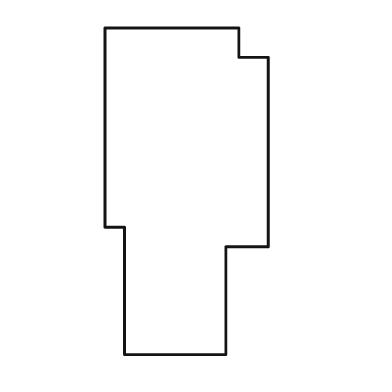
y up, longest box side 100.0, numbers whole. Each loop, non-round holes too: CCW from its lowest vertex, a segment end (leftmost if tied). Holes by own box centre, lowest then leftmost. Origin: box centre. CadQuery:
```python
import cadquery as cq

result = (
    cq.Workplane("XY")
    .moveTo(-19.0, -50.0)
    .lineTo(12.0, -50.0)
    .lineTo(12.0, -17.0)
    .lineTo(25.0, -17.0)
    .lineTo(25.0, 41.0)
    .lineTo(16.0, 41.0)
    .lineTo(16.0, 50.0)
    .lineTo(-25.0, 50.0)
    .lineTo(-25.0, -11.0)
    .lineTo(-19.0, -11.0)
    .close()
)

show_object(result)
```